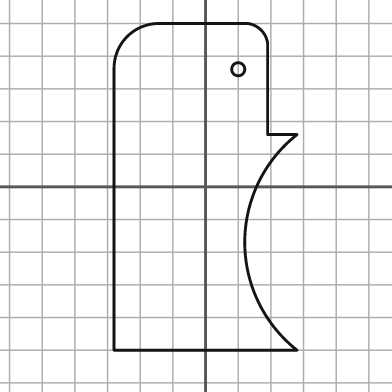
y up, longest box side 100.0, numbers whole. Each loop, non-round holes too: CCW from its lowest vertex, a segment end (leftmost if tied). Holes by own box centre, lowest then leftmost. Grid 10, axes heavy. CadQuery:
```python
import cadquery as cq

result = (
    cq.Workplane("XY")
    .moveTo(-28.0, -50.0)
    .lineTo(28.0, -50.0)
    .threePointArc((12.0, -17.0), (28.0, 16.0))
    .lineTo(19.0, 16.0)
    .lineTo(19.0, 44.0)
    .threePointArc((17.0, 48.0), (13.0, 50.0))
    .lineTo(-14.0, 50.0)
    .threePointArc((-24.0, 46.0), (-28.0, 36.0))
    .close()
    .moveTo(10.0, 36.0)
    .circle(2.0)
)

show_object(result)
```